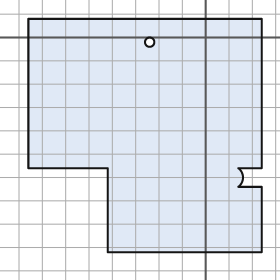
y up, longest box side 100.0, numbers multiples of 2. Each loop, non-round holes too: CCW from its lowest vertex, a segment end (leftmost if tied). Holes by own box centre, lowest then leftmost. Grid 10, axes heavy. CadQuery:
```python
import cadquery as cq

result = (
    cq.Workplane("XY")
    .moveTo(-42.0, -92.0)
    .lineTo(24.0, -92.0)
    .lineTo(24.0, -64.0)
    .lineTo(14.0, -64.0)
    .threePointArc((16.0, -60.0), (14.0, -56.0))
    .lineTo(24.0, -56.0)
    .lineTo(24.0, 8.0)
    .lineTo(-76.0, 8.0)
    .lineTo(-76.0, -56.0)
    .lineTo(-42.0, -56.0)
    .close()
    .moveTo(-24.0, -2.0)
    .circle(2.0)
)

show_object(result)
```